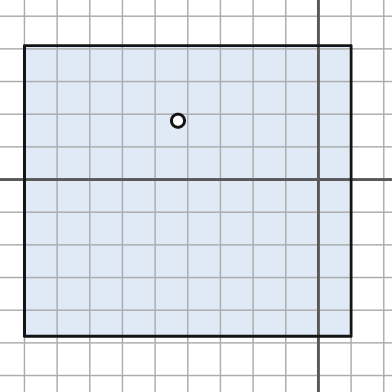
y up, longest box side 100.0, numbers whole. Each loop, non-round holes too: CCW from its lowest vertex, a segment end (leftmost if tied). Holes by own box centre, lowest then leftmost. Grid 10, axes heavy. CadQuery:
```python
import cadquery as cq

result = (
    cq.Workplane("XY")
    .moveTo(-90.0, -48.0)
    .lineTo(10.0, -48.0)
    .lineTo(10.0, 41.0)
    .lineTo(-90.0, 41.0)
    .close()
    .moveTo(-43.0, 18.0)
    .circle(2.0)
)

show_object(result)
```